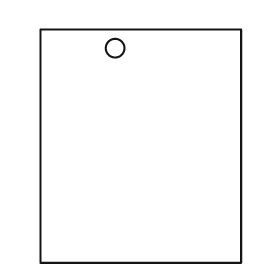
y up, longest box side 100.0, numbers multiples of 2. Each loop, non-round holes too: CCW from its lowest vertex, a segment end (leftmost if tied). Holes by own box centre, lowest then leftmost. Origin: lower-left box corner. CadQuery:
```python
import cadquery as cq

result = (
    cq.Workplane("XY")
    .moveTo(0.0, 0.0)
    .lineTo(86.0, 0.0)
    .lineTo(86.0, 100.0)
    .lineTo(0.0, 100.0)
    .close()
    .moveTo(32.0, 92.0)
    .circle(4.0)
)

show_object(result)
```